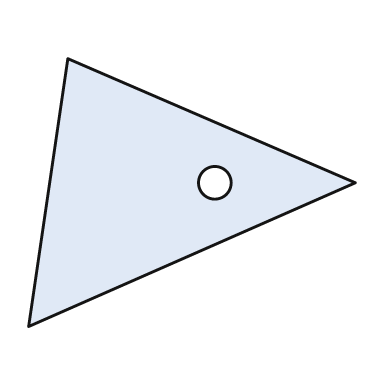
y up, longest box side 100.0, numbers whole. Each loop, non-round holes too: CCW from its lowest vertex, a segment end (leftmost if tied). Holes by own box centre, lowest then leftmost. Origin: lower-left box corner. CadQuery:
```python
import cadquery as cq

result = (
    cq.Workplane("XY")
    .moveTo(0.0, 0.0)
    .lineTo(100.0, 44.0)
    .lineTo(12.0, 82.0)
    .close()
    .moveTo(57.0, 44.0)
    .circle(5.0)
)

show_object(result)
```